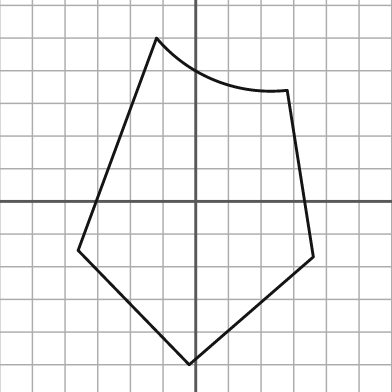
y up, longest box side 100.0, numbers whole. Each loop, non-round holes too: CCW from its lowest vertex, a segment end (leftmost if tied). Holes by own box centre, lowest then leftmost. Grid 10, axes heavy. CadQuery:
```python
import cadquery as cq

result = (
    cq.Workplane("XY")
    .moveTo(-2.0, -50.0)
    .lineTo(36.0, -17.0)
    .lineTo(28.0, 34.0)
    .threePointArc((6.0, 37.0), (-12.0, 50.0))
    .lineTo(-36.0, -15.0)
    .close()
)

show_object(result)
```